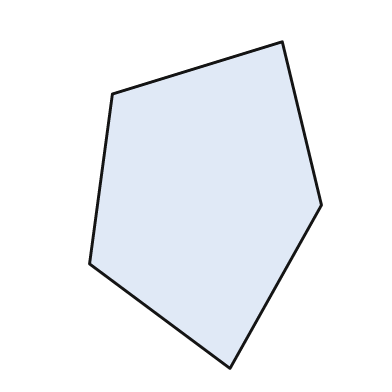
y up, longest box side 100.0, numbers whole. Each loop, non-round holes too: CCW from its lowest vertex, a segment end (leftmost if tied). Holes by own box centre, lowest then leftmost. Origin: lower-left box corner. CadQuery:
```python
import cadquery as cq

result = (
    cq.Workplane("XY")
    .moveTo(43.0, 0.0)
    .lineTo(71.0, 50.0)
    .lineTo(59.0, 100.0)
    .lineTo(7.0, 84.0)
    .lineTo(0.0, 32.0)
    .close()
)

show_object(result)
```